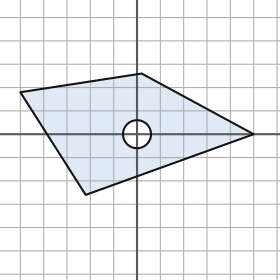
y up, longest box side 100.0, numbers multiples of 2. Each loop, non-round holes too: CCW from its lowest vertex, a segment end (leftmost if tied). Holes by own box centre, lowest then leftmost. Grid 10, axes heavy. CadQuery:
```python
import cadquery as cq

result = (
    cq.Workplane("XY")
    .moveTo(-22.0, -26.0)
    .lineTo(50.0, 0.0)
    .lineTo(2.0, 26.0)
    .lineTo(-50.0, 18.0)
    .close()
    .moveTo(0.0, 0.0)
    .circle(6.0)
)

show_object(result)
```